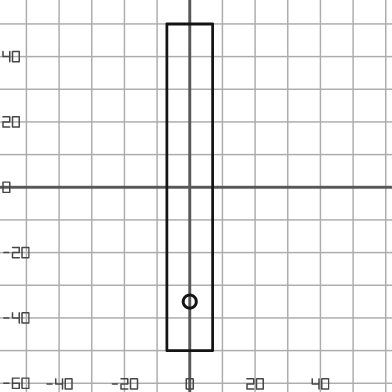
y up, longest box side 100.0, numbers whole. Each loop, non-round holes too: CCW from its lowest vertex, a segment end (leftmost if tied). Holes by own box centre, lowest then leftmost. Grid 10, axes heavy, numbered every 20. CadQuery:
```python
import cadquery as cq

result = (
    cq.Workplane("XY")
    .moveTo(-7.0, -50.0)
    .lineTo(7.0, -50.0)
    .lineTo(7.0, 50.0)
    .lineTo(-7.0, 50.0)
    .close()
    .moveTo(0.0, -35.0)
    .circle(2.0)
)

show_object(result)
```